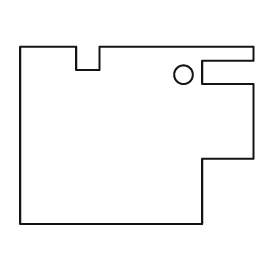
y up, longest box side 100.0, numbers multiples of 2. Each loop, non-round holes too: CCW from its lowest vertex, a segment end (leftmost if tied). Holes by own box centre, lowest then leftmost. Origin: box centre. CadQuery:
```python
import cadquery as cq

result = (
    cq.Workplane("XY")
    .moveTo(-50.0, -38.0)
    .lineTo(28.0, -38.0)
    .lineTo(28.0, -10.0)
    .lineTo(50.0, -10.0)
    .lineTo(50.0, 22.0)
    .lineTo(28.0, 22.0)
    .lineTo(28.0, 32.0)
    .lineTo(50.0, 32.0)
    .lineTo(50.0, 38.0)
    .lineTo(-16.0, 38.0)
    .lineTo(-16.0, 28.0)
    .lineTo(-26.0, 28.0)
    .lineTo(-26.0, 38.0)
    .lineTo(-50.0, 38.0)
    .close()
    .moveTo(20.0, 26.0)
    .circle(4.0)
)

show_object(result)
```